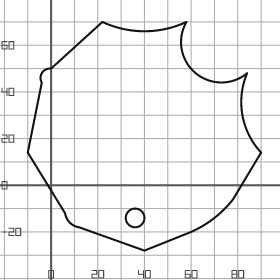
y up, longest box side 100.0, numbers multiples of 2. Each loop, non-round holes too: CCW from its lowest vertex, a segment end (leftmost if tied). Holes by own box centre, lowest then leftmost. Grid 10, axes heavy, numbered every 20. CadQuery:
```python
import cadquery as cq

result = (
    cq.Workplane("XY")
    .moveTo(40.0, -28.0)
    .lineTo(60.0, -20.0)
    .threePointArc((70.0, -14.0), (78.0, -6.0))
    .lineTo(90.0, 14.0)
    .threePointArc((82.0, 30.0), (84.0, 48.0))
    .threePointArc((62.0, 48.0), (58.0, 70.0))
    .threePointArc((40.0, 66.0), (22.0, 70.0))
    .lineTo(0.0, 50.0)
    .threePointArc((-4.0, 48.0), (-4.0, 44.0))
    .lineTo(-10.0, 14.0)
    .lineTo(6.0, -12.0)
    .threePointArc((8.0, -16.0), (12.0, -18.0))
    .close()
    .moveTo(36.0, -14.0)
    .circle(4.0)
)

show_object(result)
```